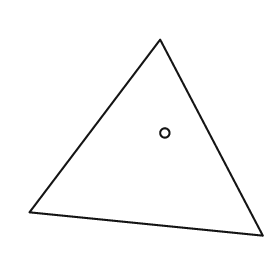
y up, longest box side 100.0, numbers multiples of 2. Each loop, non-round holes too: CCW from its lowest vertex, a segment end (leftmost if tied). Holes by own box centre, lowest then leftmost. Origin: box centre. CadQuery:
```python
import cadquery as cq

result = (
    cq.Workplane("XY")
    .moveTo(50.0, -42.0)
    .lineTo(6.0, 42.0)
    .lineTo(-50.0, -32.0)
    .close()
    .moveTo(8.0, 2.0)
    .circle(2.0)
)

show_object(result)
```